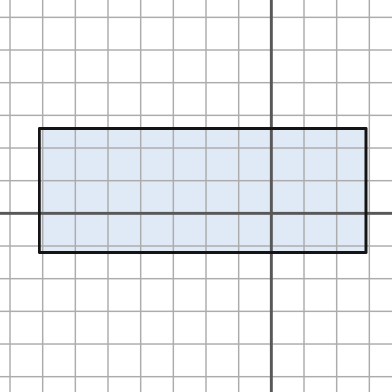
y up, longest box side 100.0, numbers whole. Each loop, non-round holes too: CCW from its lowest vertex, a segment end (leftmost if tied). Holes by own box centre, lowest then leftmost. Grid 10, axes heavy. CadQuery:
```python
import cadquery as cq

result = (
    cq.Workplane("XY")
    .moveTo(-71.0, -12.0)
    .lineTo(29.0, -12.0)
    .lineTo(29.0, 26.0)
    .lineTo(-71.0, 26.0)
    .close()
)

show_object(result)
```